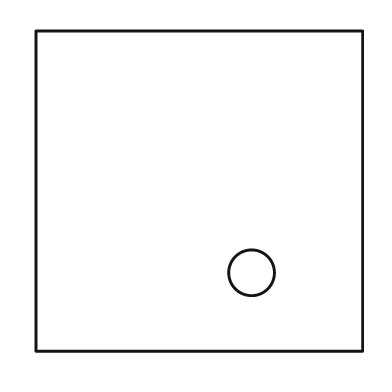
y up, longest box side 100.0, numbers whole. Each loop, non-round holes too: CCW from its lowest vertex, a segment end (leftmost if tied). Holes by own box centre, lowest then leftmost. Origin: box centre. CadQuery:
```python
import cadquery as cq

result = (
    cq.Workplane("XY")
    .moveTo(-50.0, -49.0)
    .lineTo(50.0, -49.0)
    .lineTo(50.0, 49.0)
    .lineTo(-50.0, 49.0)
    .close()
    .moveTo(16.0, -25.0)
    .circle(7.0)
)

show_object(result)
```